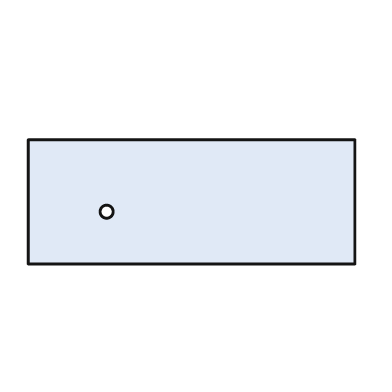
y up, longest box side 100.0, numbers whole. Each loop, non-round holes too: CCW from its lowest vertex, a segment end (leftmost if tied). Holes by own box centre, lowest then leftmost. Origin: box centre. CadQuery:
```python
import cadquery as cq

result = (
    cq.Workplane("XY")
    .moveTo(-50.0, -19.0)
    .lineTo(50.0, -19.0)
    .lineTo(50.0, 19.0)
    .lineTo(-50.0, 19.0)
    .close()
    .moveTo(-26.0, -3.0)
    .circle(2.0)
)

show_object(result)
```